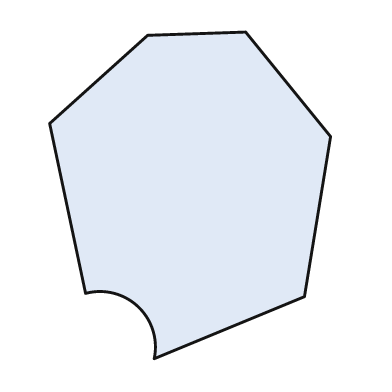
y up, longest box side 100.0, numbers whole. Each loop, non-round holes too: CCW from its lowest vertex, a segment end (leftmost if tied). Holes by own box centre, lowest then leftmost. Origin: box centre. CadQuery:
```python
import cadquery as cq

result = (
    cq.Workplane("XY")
    .moveTo(-11.0, -50.0)
    .lineTo(35.0, -31.0)
    .lineTo(43.0, 18.0)
    .lineTo(17.0, 50.0)
    .lineTo(-13.0, 49.0)
    .lineTo(-43.0, 22.0)
    .lineTo(-32.0, -30.0)
    .threePointArc((-16.0, -34.0), (-11.0, -50.0))
    .close()
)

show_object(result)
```